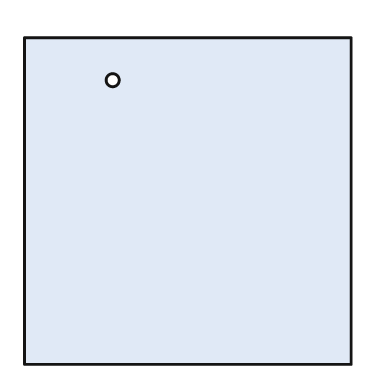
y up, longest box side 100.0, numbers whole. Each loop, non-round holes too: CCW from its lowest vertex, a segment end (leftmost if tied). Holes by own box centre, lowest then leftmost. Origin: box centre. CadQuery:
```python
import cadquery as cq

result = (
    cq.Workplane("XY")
    .moveTo(-50.0, -50.0)
    .lineTo(50.0, -50.0)
    .lineTo(50.0, 50.0)
    .lineTo(-50.0, 50.0)
    .close()
    .moveTo(-23.0, 37.0)
    .circle(2.0)
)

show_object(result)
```